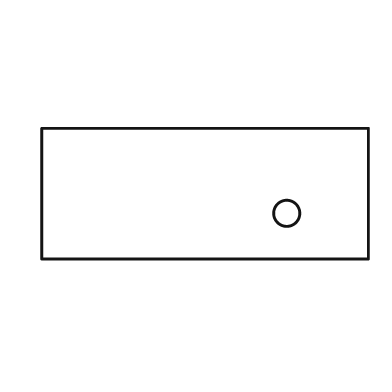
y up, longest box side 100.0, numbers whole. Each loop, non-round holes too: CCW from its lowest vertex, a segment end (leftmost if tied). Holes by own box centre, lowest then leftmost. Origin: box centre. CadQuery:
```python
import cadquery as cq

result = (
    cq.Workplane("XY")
    .moveTo(-50.0, -20.0)
    .lineTo(50.0, -20.0)
    .lineTo(50.0, 20.0)
    .lineTo(-50.0, 20.0)
    .close()
    .moveTo(25.0, -6.0)
    .circle(4.0)
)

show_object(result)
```